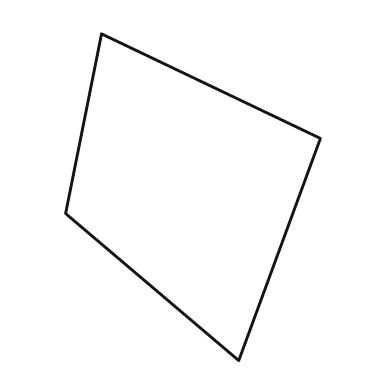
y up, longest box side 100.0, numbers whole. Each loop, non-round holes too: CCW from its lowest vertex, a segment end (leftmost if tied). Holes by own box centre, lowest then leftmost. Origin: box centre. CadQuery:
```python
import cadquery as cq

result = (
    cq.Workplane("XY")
    .moveTo(14.0, -50.0)
    .lineTo(39.0, 18.0)
    .lineTo(-28.0, 50.0)
    .lineTo(-39.0, -5.0)
    .close()
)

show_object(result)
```